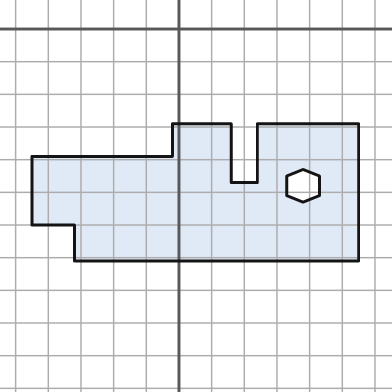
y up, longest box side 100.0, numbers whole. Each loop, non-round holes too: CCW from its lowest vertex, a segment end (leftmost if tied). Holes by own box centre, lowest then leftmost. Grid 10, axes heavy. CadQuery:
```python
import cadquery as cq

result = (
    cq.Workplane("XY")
    .moveTo(-32.0, -71.0)
    .lineTo(55.0, -71.0)
    .lineTo(55.0, -29.0)
    .lineTo(24.0, -29.0)
    .lineTo(24.0, -47.0)
    .lineTo(16.0, -47.0)
    .lineTo(16.0, -29.0)
    .lineTo(-2.0, -29.0)
    .lineTo(-2.0, -39.0)
    .lineTo(-45.0, -39.0)
    .lineTo(-45.0, -60.0)
    .lineTo(-32.0, -60.0)
    .close()
    .moveTo(38.0, -53.0)
    .lineTo(43.0, -51.0)
    .lineTo(43.0, -45.0)
    .lineTo(38.0, -43.0)
    .lineTo(33.0, -45.0)
    .lineTo(33.0, -51.0)
    .close()
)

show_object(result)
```